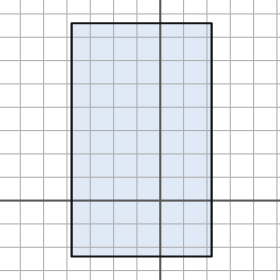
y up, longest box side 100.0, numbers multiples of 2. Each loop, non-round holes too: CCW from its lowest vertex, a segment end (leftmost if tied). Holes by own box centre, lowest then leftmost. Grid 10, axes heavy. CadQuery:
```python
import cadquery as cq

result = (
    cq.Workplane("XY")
    .moveTo(-38.0, -24.0)
    .lineTo(22.0, -24.0)
    .lineTo(22.0, 76.0)
    .lineTo(-38.0, 76.0)
    .close()
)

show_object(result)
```